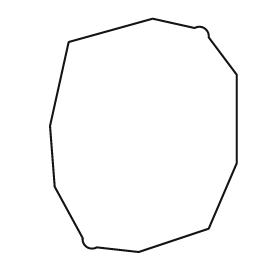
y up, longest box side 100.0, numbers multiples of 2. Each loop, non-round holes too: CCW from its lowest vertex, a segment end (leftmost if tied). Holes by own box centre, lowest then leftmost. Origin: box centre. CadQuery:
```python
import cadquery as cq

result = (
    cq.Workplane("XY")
    .moveTo(-2.0, -50.0)
    .lineTo(28.0, -40.0)
    .lineTo(40.0, -12.0)
    .lineTo(40.0, 26.0)
    .lineTo(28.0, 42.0)
    .threePointArc((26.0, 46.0), (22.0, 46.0))
    .lineTo(4.0, 50.0)
    .lineTo(-32.0, 40.0)
    .lineTo(-40.0, 4.0)
    .lineTo(-38.0, -22.0)
    .lineTo(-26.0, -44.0)
    .threePointArc((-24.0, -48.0), (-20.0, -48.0))
    .close()
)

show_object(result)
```